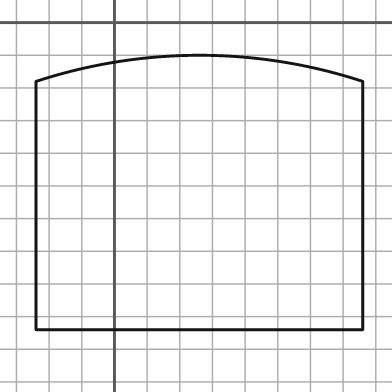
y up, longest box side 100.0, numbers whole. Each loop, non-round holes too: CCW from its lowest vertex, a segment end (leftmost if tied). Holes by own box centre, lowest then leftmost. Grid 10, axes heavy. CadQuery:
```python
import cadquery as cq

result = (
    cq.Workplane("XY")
    .moveTo(-24.0, -94.0)
    .lineTo(76.0, -94.0)
    .lineTo(76.0, -18.0)
    .threePointArc((26.0, -10.0), (-24.0, -18.0))
    .close()
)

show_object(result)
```